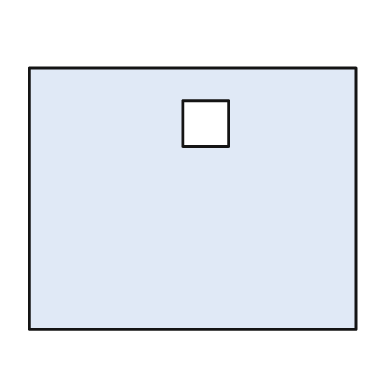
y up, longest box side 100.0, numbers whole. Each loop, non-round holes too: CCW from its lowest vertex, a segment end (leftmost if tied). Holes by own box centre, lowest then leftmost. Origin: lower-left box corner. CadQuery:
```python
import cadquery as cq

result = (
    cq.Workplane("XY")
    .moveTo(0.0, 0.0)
    .lineTo(100.0, 0.0)
    .lineTo(100.0, 80.0)
    .lineTo(0.0, 80.0)
    .close()
    .moveTo(47.0, 56.0)
    .lineTo(61.0, 56.0)
    .lineTo(61.0, 70.0)
    .lineTo(47.0, 70.0)
    .close()
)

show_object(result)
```